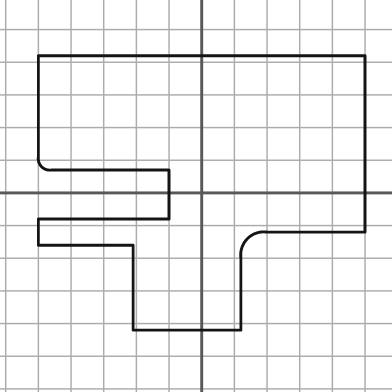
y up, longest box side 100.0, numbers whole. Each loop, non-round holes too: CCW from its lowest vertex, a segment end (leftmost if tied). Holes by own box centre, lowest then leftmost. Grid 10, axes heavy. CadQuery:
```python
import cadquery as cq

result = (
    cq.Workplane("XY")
    .moveTo(-21.0, -42.0)
    .lineTo(12.0, -42.0)
    .lineTo(12.0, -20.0)
    .threePointArc((14.0, -14.0), (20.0, -12.0))
    .lineTo(50.0, -12.0)
    .lineTo(50.0, 42.0)
    .lineTo(-50.0, 42.0)
    .lineTo(-50.0, 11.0)
    .threePointArc((-49.0, 8.0), (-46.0, 7.0))
    .lineTo(-10.0, 7.0)
    .lineTo(-10.0, -8.0)
    .lineTo(-50.0, -8.0)
    .lineTo(-50.0, -16.0)
    .lineTo(-21.0, -16.0)
    .close()
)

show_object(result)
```